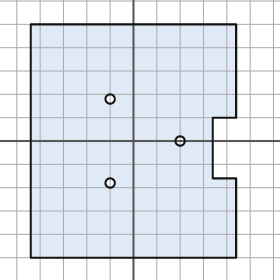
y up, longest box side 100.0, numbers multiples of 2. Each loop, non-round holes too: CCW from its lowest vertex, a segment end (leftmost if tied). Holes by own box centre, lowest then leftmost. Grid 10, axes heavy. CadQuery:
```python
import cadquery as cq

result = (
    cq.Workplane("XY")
    .moveTo(-44.0, -50.0)
    .lineTo(44.0, -50.0)
    .lineTo(44.0, -16.0)
    .lineTo(34.0, -16.0)
    .lineTo(34.0, 10.0)
    .lineTo(44.0, 10.0)
    .lineTo(44.0, 50.0)
    .lineTo(-44.0, 50.0)
    .close()
    .moveTo(-10.0, -18.0)
    .circle(2.0)
    .moveTo(20.0, 0.0)
    .circle(2.0)
    .moveTo(-10.0, 18.0)
    .circle(2.0)
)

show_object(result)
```